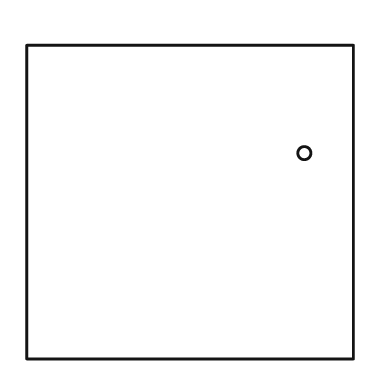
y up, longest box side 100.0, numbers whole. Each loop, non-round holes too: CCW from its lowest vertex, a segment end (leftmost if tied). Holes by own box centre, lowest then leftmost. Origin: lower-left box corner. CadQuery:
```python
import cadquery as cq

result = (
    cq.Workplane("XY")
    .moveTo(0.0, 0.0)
    .lineTo(100.0, 0.0)
    .lineTo(100.0, 96.0)
    .lineTo(0.0, 96.0)
    .close()
    .moveTo(85.0, 63.0)
    .circle(2.0)
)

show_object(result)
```